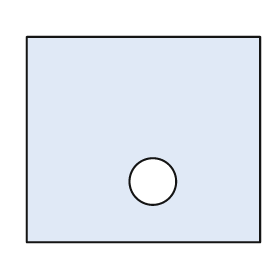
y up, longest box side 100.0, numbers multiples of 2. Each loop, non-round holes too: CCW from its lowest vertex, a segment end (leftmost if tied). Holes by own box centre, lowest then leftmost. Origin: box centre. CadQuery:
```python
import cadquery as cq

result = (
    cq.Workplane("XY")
    .moveTo(-50.0, -44.0)
    .lineTo(50.0, -44.0)
    .lineTo(50.0, 44.0)
    .lineTo(-50.0, 44.0)
    .close()
    .moveTo(4.0, -18.0)
    .circle(10.0)
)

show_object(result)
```